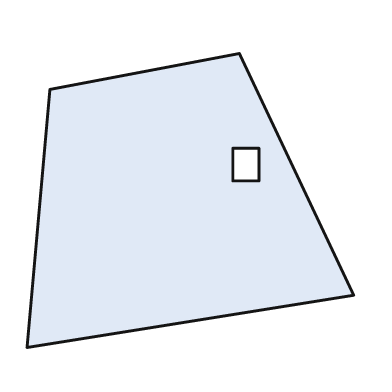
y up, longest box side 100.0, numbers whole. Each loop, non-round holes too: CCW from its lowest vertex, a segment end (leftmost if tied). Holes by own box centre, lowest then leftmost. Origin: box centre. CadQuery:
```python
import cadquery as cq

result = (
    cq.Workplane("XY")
    .moveTo(-50.0, -45.0)
    .lineTo(50.0, -29.0)
    .lineTo(15.0, 45.0)
    .lineTo(-43.0, 34.0)
    .close()
    .moveTo(13.0, 6.0)
    .lineTo(21.0, 6.0)
    .lineTo(21.0, 16.0)
    .lineTo(13.0, 16.0)
    .close()
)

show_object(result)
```